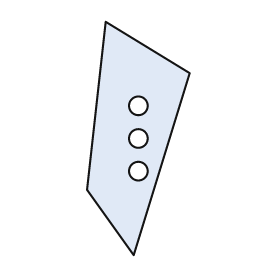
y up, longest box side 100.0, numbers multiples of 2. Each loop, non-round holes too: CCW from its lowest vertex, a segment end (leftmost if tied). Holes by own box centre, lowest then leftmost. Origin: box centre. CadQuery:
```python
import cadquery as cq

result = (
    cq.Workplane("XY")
    .moveTo(-2.0, -50.0)
    .lineTo(22.0, 28.0)
    .lineTo(-14.0, 50.0)
    .lineTo(-22.0, -22.0)
    .close()
    .moveTo(0.0, -14.0)
    .circle(4.0)
    .moveTo(0.0, 0.0)
    .circle(4.0)
    .moveTo(0.0, 14.0)
    .circle(4.0)
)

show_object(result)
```